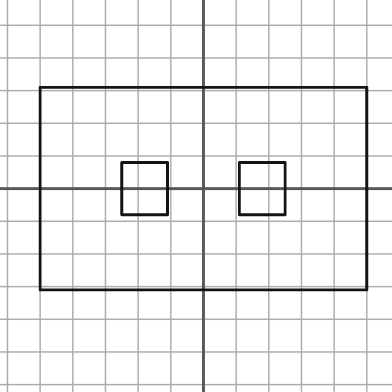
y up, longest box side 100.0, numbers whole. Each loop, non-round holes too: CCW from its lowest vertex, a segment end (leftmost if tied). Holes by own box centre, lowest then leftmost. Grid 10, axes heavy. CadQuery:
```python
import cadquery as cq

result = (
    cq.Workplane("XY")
    .moveTo(-50.0, -31.0)
    .lineTo(50.0, -31.0)
    .lineTo(50.0, 31.0)
    .lineTo(-50.0, 31.0)
    .close()
    .moveTo(-25.0, -8.0)
    .lineTo(-11.0, -8.0)
    .lineTo(-11.0, 8.0)
    .lineTo(-25.0, 8.0)
    .close()
    .moveTo(11.0, -8.0)
    .lineTo(25.0, -8.0)
    .lineTo(25.0, 8.0)
    .lineTo(11.0, 8.0)
    .close()
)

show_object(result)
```